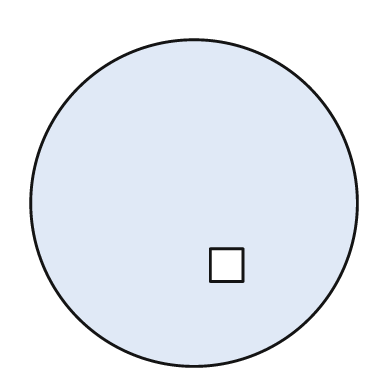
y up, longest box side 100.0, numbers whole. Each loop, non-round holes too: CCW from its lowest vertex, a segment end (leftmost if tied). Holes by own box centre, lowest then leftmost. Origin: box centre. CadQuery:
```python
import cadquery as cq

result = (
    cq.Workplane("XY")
    .moveTo(0.0, 0.0)
    .circle(50.0)
    .moveTo(5.0, -24.0)
    .lineTo(15.0, -24.0)
    .lineTo(15.0, -14.0)
    .lineTo(5.0, -14.0)
    .close()
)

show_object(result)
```